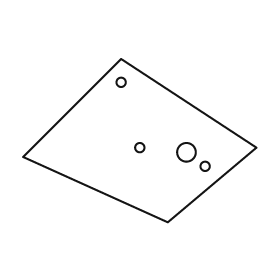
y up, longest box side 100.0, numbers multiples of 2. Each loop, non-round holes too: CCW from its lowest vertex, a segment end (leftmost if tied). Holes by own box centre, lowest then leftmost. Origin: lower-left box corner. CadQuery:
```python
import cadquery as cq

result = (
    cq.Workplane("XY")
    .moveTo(62.0, 0.0)
    .lineTo(100.0, 32.0)
    .lineTo(42.0, 70.0)
    .lineTo(0.0, 28.0)
    .close()
    .moveTo(78.0, 24.0)
    .circle(2.0)
    .moveTo(70.0, 30.0)
    .circle(4.0)
    .moveTo(50.0, 32.0)
    .circle(2.0)
    .moveTo(42.0, 60.0)
    .circle(2.0)
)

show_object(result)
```